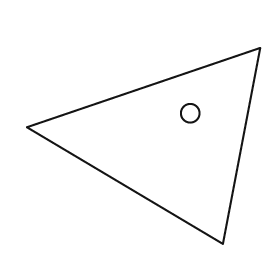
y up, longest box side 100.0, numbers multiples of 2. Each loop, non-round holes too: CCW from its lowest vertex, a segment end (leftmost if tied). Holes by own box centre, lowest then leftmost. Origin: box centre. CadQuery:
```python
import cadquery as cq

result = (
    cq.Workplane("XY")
    .moveTo(34.0, -42.0)
    .lineTo(50.0, 42.0)
    .lineTo(-50.0, 8.0)
    .close()
    .moveTo(20.0, 14.0)
    .circle(4.0)
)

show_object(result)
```